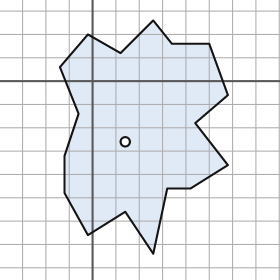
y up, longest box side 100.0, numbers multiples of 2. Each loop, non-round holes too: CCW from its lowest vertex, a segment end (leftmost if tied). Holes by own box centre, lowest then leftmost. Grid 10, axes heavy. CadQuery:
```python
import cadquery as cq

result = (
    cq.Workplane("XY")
    .moveTo(26.0, -74.0)
    .lineTo(32.0, -46.0)
    .lineTo(42.0, -46.0)
    .lineTo(58.0, -36.0)
    .lineTo(44.0, -18.0)
    .lineTo(58.0, -6.0)
    .lineTo(50.0, 16.0)
    .lineTo(34.0, 16.0)
    .lineTo(26.0, 26.0)
    .lineTo(12.0, 12.0)
    .lineTo(-2.0, 20.0)
    .lineTo(-14.0, 6.0)
    .lineTo(-6.0, -14.0)
    .lineTo(-12.0, -32.0)
    .lineTo(-12.0, -48.0)
    .lineTo(-2.0, -66.0)
    .lineTo(14.0, -56.0)
    .close()
    .moveTo(14.0, -26.0)
    .circle(2.0)
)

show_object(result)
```